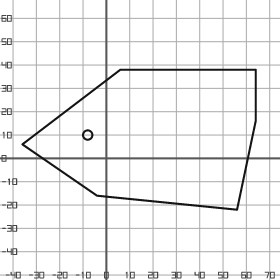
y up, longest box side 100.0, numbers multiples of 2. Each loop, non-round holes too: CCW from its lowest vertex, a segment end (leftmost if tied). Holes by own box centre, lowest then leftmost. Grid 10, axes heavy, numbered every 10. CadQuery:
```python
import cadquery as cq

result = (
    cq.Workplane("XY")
    .moveTo(56.0, -22.0)
    .lineTo(64.0, 16.0)
    .lineTo(64.0, 38.0)
    .lineTo(6.0, 38.0)
    .lineTo(-36.0, 6.0)
    .lineTo(-4.0, -16.0)
    .close()
    .moveTo(-8.0, 10.0)
    .circle(2.0)
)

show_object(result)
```